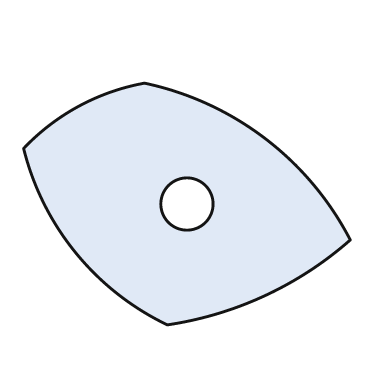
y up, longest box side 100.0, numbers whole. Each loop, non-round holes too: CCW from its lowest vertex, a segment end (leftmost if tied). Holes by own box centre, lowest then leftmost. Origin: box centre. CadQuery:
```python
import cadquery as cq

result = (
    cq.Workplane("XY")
    .moveTo(-6.0, -37.0)
    .threePointArc((24.0, -28.0), (50.0, -11.0))
    .threePointArc((24.0, 20.0), (-13.0, 37.0))
    .threePointArc((-33.0, 30.0), (-50.0, 17.0))
    .threePointArc((-34.0, -15.0), (-6.0, -37.0))
    .close()
    .moveTo(0.0, 0.0)
    .circle(8.0)
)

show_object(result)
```